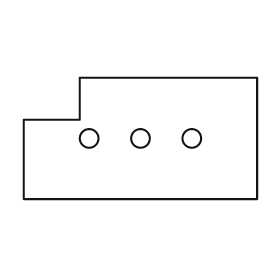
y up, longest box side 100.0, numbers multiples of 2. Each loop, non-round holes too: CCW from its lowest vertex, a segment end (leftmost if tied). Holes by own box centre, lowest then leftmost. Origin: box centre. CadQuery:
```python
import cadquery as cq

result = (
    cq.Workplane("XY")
    .moveTo(-50.0, -26.0)
    .lineTo(50.0, -26.0)
    .lineTo(50.0, 26.0)
    .lineTo(-26.0, 26.0)
    .lineTo(-26.0, 8.0)
    .lineTo(-50.0, 8.0)
    .close()
    .moveTo(-22.0, 0.0)
    .circle(4.0)
    .moveTo(0.0, 0.0)
    .circle(4.0)
    .moveTo(22.0, 0.0)
    .circle(4.0)
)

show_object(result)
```